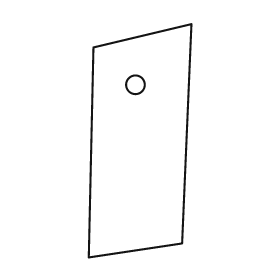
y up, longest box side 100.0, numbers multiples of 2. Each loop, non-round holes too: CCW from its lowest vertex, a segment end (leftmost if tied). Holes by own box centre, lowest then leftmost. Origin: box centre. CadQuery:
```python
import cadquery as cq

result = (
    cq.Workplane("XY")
    .moveTo(-22.0, -50.0)
    .lineTo(18.0, -44.0)
    .lineTo(22.0, 50.0)
    .lineTo(-20.0, 40.0)
    .close()
    .moveTo(-2.0, 24.0)
    .circle(4.0)
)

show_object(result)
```